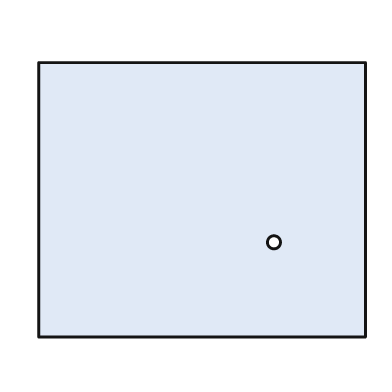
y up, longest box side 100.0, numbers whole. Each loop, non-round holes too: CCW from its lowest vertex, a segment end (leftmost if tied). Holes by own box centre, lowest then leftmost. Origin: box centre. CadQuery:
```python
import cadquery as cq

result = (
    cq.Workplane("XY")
    .moveTo(-50.0, -42.0)
    .lineTo(50.0, -42.0)
    .lineTo(50.0, 42.0)
    .lineTo(-50.0, 42.0)
    .close()
    .moveTo(22.0, -13.0)
    .circle(2.0)
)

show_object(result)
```